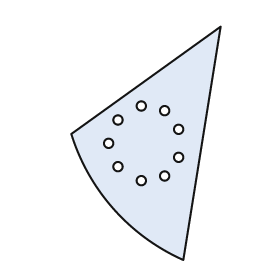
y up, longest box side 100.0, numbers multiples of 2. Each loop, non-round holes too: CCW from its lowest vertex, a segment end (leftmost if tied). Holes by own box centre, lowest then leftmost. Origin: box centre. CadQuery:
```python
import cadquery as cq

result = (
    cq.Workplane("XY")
    .moveTo(16.0, -50.0)
    .lineTo(32.0, 50.0)
    .lineTo(-32.0, 4.0)
    .threePointArc((-14.0, -28.0), (16.0, -50.0))
    .close()
    .moveTo(-2.0, -16.0)
    .circle(2.0)
    .moveTo(8.0, -14.0)
    .circle(2.0)
    .moveTo(-12.0, -10.0)
    .circle(2.0)
    .moveTo(14.0, -6.0)
    .circle(2.0)
    .moveTo(-16.0, 0.0)
    .circle(2.0)
    .moveTo(14.0, 6.0)
    .circle(2.0)
    .moveTo(-12.0, 10.0)
    .circle(2.0)
    .moveTo(8.0, 14.0)
    .circle(2.0)
    .moveTo(-2.0, 16.0)
    .circle(2.0)
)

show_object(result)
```